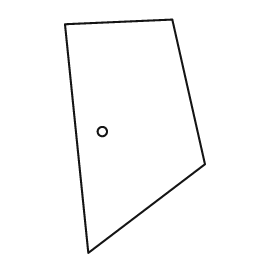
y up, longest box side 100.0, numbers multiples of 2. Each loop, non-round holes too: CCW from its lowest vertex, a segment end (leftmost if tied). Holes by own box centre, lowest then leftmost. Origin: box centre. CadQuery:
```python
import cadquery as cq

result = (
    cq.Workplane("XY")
    .moveTo(-20.0, -50.0)
    .lineTo(30.0, -12.0)
    .lineTo(16.0, 50.0)
    .lineTo(-30.0, 48.0)
    .close()
    .moveTo(-14.0, 2.0)
    .circle(2.0)
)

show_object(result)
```